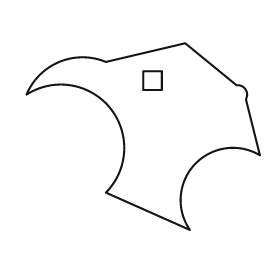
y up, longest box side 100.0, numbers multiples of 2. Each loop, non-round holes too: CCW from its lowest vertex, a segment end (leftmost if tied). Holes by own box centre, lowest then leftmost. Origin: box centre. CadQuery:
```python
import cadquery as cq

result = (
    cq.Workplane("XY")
    .moveTo(20.0, -40.0)
    .threePointArc((22.0, -12.0), (50.0, -8.0))
    .lineTo(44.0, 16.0)
    .threePointArc((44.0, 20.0), (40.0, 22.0))
    .lineTo(18.0, 40.0)
    .lineTo(-16.0, 32.0)
    .threePointArc((-36.0, 32.0), (-50.0, 18.0))
    .threePointArc((-14.0, 12.0), (-16.0, -24.0))
    .close()
    .moveTo(0.0, 20.0)
    .lineTo(8.0, 20.0)
    .lineTo(8.0, 28.0)
    .lineTo(0.0, 28.0)
    .close()
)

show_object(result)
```